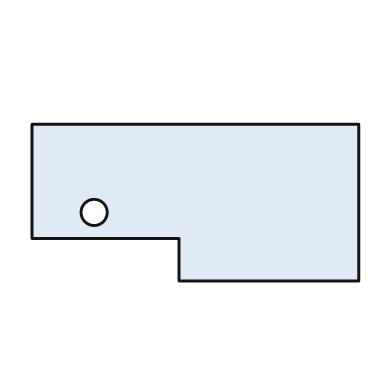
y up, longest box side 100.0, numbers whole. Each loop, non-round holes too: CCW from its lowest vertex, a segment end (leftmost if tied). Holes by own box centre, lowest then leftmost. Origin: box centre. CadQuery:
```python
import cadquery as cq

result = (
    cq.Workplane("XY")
    .moveTo(-5.0, -24.0)
    .lineTo(50.0, -24.0)
    .lineTo(50.0, 24.0)
    .lineTo(-50.0, 24.0)
    .lineTo(-50.0, -11.0)
    .lineTo(-5.0, -11.0)
    .close()
    .moveTo(-31.0, -3.0)
    .circle(4.0)
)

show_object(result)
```